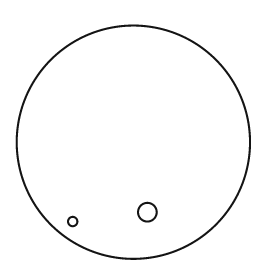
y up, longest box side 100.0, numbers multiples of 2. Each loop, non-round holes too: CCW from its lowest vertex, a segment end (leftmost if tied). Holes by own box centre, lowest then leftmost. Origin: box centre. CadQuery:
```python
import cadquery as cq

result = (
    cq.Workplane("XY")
    .moveTo(0.0, 0.0)
    .circle(50.0)
    .moveTo(-26.0, -34.0)
    .circle(2.0)
    .moveTo(6.0, -30.0)
    .circle(4.0)
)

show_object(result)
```